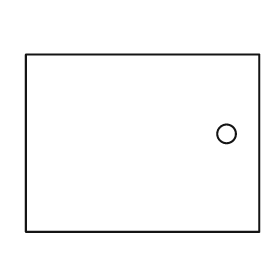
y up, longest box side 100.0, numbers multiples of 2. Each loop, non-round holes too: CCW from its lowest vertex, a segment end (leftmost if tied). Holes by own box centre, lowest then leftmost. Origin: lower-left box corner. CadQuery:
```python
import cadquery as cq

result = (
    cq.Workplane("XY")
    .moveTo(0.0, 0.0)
    .lineTo(100.0, 0.0)
    .lineTo(100.0, 76.0)
    .lineTo(0.0, 76.0)
    .close()
    .moveTo(86.0, 42.0)
    .circle(4.0)
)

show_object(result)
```